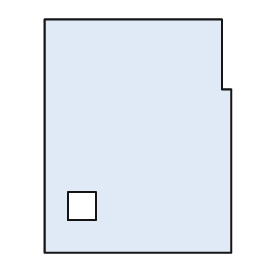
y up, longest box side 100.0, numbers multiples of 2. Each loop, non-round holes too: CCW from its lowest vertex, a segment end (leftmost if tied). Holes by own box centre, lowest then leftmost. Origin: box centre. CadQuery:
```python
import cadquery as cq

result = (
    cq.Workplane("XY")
    .moveTo(-40.0, -50.0)
    .lineTo(40.0, -50.0)
    .lineTo(40.0, 20.0)
    .lineTo(36.0, 20.0)
    .lineTo(36.0, 50.0)
    .lineTo(-40.0, 50.0)
    .close()
    .moveTo(-30.0, -36.0)
    .lineTo(-18.0, -36.0)
    .lineTo(-18.0, -24.0)
    .lineTo(-30.0, -24.0)
    .close()
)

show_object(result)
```